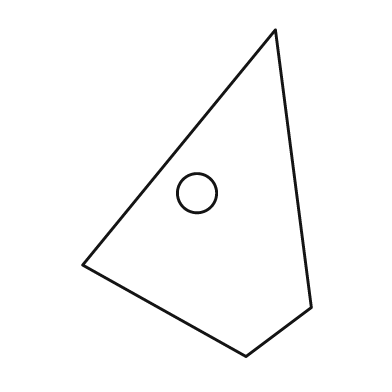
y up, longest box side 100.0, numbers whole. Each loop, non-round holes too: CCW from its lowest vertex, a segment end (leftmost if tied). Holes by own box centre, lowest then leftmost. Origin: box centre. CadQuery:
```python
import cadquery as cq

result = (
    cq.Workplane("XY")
    .moveTo(15.0, -50.0)
    .lineTo(35.0, -35.0)
    .lineTo(24.0, 50.0)
    .lineTo(-35.0, -22.0)
    .close()
    .moveTo(0.0, 0.0)
    .circle(6.0)
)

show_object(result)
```